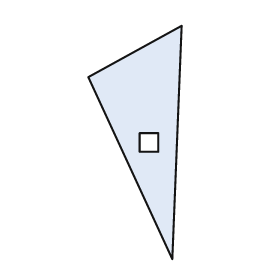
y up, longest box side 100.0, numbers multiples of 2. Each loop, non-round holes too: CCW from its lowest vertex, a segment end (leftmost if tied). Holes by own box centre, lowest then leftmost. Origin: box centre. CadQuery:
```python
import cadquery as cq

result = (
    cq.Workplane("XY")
    .moveTo(16.0, -50.0)
    .lineTo(20.0, 50.0)
    .lineTo(-20.0, 28.0)
    .close()
    .moveTo(2.0, -4.0)
    .lineTo(10.0, -4.0)
    .lineTo(10.0, 4.0)
    .lineTo(2.0, 4.0)
    .close()
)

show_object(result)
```